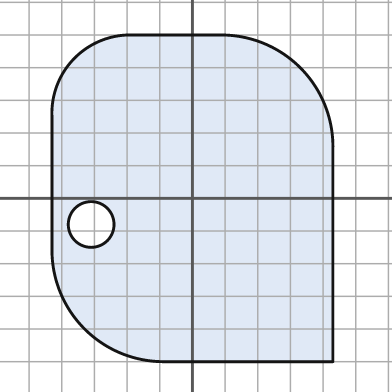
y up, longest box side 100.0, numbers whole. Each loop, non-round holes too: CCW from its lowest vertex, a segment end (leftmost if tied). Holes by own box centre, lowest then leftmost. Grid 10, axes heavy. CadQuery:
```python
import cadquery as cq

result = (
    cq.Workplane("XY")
    .moveTo(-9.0, -50.0)
    .lineTo(43.0, -50.0)
    .lineTo(43.0, 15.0)
    .threePointArc((33.0, 40.0), (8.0, 50.0))
    .lineTo(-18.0, 50.0)
    .threePointArc((-36.0, 43.0), (-43.0, 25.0))
    .lineTo(-43.0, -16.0)
    .threePointArc((-33.0, -40.0), (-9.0, -50.0))
    .close()
    .moveTo(-31.0, -8.0)
    .circle(7.0)
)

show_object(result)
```